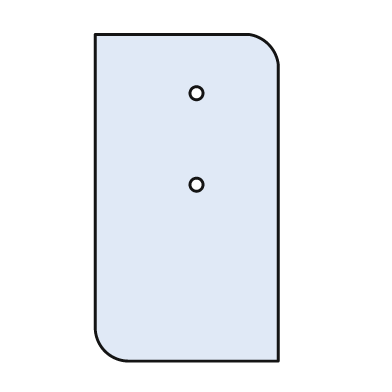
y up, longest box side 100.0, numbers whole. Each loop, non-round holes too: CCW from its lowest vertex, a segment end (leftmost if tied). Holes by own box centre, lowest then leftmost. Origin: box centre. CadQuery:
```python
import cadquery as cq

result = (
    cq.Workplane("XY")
    .moveTo(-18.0, -50.0)
    .lineTo(28.0, -50.0)
    .lineTo(28.0, 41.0)
    .threePointArc((25.0, 47.0), (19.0, 50.0))
    .lineTo(-28.0, 50.0)
    .lineTo(-28.0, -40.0)
    .threePointArc((-25.0, -47.0), (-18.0, -50.0))
    .close()
    .moveTo(3.0, 4.0)
    .circle(2.0)
    .moveTo(3.0, 32.0)
    .circle(2.0)
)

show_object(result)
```